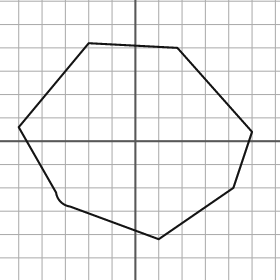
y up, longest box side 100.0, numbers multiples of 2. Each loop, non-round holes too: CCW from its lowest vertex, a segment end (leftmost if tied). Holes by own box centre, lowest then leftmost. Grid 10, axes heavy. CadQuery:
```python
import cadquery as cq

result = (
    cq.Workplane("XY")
    .moveTo(10.0, -42.0)
    .lineTo(42.0, -20.0)
    .lineTo(50.0, 4.0)
    .lineTo(18.0, 40.0)
    .lineTo(-20.0, 42.0)
    .lineTo(-50.0, 6.0)
    .lineTo(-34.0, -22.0)
    .threePointArc((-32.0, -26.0), (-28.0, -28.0))
    .close()
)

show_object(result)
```